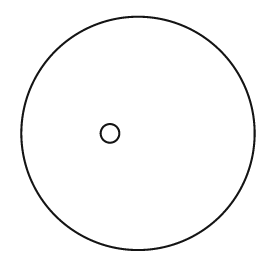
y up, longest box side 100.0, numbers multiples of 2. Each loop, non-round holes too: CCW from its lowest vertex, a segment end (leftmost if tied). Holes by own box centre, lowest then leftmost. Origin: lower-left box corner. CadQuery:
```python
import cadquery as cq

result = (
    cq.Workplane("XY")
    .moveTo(50.0, 50.0)
    .circle(50.0)
    .moveTo(38.0, 50.0)
    .circle(4.0)
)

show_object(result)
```